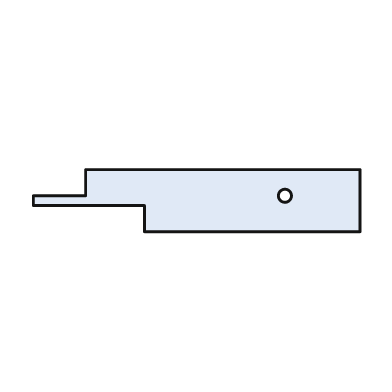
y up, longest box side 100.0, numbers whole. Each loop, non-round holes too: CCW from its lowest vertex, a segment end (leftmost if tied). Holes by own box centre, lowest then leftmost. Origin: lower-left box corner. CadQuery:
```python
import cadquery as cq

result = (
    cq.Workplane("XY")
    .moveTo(34.0, 0.0)
    .lineTo(100.0, 0.0)
    .lineTo(100.0, 19.0)
    .lineTo(16.0, 19.0)
    .lineTo(16.0, 11.0)
    .lineTo(0.0, 11.0)
    .lineTo(0.0, 8.0)
    .lineTo(34.0, 8.0)
    .close()
    .moveTo(77.0, 11.0)
    .circle(2.0)
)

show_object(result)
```